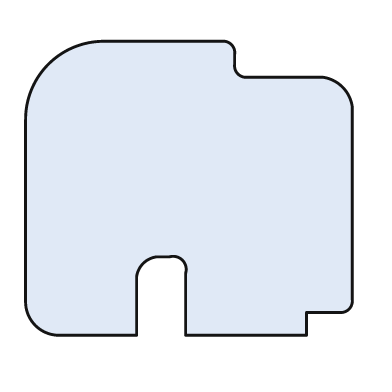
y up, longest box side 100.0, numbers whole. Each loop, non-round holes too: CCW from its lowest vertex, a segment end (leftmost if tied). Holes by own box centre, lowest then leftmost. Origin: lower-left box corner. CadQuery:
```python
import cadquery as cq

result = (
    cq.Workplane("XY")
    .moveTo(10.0, 0.0)
    .lineTo(34.0, 0.0)
    .lineTo(34.0, 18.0)
    .threePointArc((36.0, 22.0), (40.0, 24.0))
    .lineTo(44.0, 24.0)
    .threePointArc((48.0, 23.0), (49.0, 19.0))
    .lineTo(49.0, 0.0)
    .lineTo(86.0, 0.0)
    .lineTo(86.0, 7.0)
    .lineTo(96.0, 7.0)
    .threePointArc((99.0, 8.0), (100.0, 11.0))
    .lineTo(100.0, 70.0)
    .threePointArc((97.0, 76.0), (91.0, 79.0))
    .lineTo(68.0, 79.0)
    .threePointArc((65.0, 80.0), (64.0, 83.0))
    .lineTo(64.0, 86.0)
    .threePointArc((63.0, 89.0), (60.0, 90.0))
    .lineTo(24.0, 90.0)
    .threePointArc((7.0, 83.0), (0.0, 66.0))
    .lineTo(0.0, 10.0)
    .threePointArc((3.0, 3.0), (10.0, 0.0))
    .close()
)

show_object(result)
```